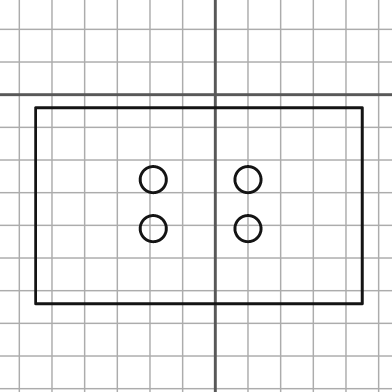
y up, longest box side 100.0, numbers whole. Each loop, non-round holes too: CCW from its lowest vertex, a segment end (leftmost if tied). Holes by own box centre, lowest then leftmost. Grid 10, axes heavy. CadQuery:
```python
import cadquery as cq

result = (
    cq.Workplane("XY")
    .moveTo(-55.0, -64.0)
    .lineTo(45.0, -64.0)
    .lineTo(45.0, -4.0)
    .lineTo(-55.0, -4.0)
    .close()
    .moveTo(-19.0, -41.0)
    .circle(4.0)
    .moveTo(10.0, -41.0)
    .circle(4.0)
    .moveTo(-19.0, -26.0)
    .circle(4.0)
    .moveTo(10.0, -26.0)
    .circle(4.0)
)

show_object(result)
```